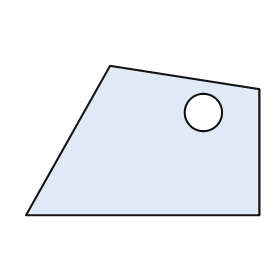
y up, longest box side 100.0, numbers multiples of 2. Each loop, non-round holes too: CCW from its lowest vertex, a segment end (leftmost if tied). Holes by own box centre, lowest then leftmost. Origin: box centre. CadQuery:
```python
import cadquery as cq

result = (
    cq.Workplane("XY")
    .moveTo(-50.0, -32.0)
    .lineTo(50.0, -32.0)
    .lineTo(50.0, 22.0)
    .lineTo(-14.0, 32.0)
    .close()
    .moveTo(26.0, 12.0)
    .circle(8.0)
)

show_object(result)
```